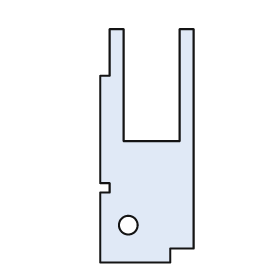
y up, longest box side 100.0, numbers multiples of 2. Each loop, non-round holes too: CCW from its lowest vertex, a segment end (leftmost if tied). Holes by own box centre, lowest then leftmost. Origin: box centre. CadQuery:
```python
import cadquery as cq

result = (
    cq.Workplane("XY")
    .moveTo(-20.0, -50.0)
    .lineTo(10.0, -50.0)
    .lineTo(10.0, -44.0)
    .lineTo(20.0, -44.0)
    .lineTo(20.0, 50.0)
    .lineTo(14.0, 50.0)
    .lineTo(14.0, 2.0)
    .lineTo(-10.0, 2.0)
    .lineTo(-10.0, 50.0)
    .lineTo(-16.0, 50.0)
    .lineTo(-16.0, 30.0)
    .lineTo(-20.0, 30.0)
    .lineTo(-20.0, -16.0)
    .lineTo(-16.0, -16.0)
    .lineTo(-16.0, -20.0)
    .lineTo(-20.0, -20.0)
    .close()
    .moveTo(-8.0, -34.0)
    .circle(4.0)
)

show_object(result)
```